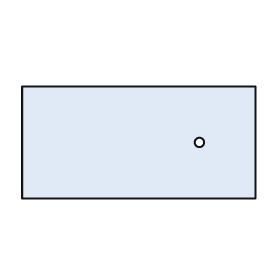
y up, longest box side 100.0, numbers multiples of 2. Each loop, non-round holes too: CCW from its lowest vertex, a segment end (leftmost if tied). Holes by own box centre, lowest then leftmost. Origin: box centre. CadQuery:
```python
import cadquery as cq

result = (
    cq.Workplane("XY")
    .moveTo(-50.0, -24.0)
    .lineTo(50.0, -24.0)
    .lineTo(50.0, 24.0)
    .lineTo(-50.0, 24.0)
    .close()
    .moveTo(26.0, 0.0)
    .circle(2.0)
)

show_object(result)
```